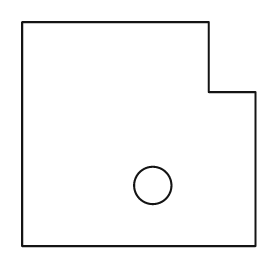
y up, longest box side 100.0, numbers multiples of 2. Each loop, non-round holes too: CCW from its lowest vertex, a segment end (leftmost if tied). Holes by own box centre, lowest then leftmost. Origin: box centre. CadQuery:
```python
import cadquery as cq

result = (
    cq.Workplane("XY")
    .moveTo(-50.0, -48.0)
    .lineTo(50.0, -48.0)
    .lineTo(50.0, 18.0)
    .lineTo(30.0, 18.0)
    .lineTo(30.0, 48.0)
    .lineTo(-50.0, 48.0)
    .close()
    .moveTo(6.0, -22.0)
    .circle(8.0)
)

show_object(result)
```